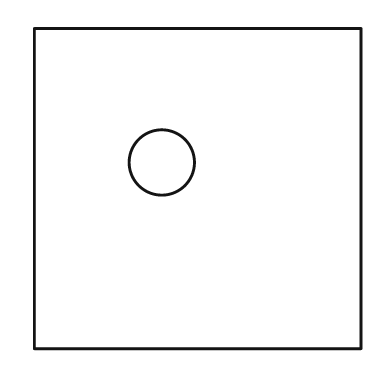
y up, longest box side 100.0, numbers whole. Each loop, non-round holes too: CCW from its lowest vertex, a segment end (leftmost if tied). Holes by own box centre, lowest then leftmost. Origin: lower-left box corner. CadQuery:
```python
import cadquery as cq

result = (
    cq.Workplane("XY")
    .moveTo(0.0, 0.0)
    .lineTo(100.0, 0.0)
    .lineTo(100.0, 98.0)
    .lineTo(0.0, 98.0)
    .close()
    .moveTo(39.0, 57.0)
    .circle(10.0)
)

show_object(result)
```